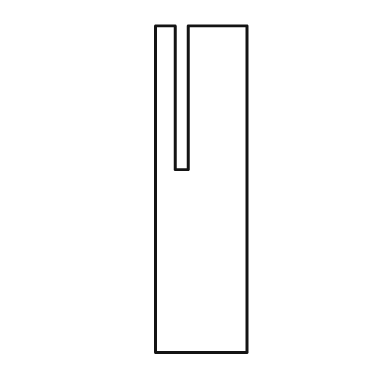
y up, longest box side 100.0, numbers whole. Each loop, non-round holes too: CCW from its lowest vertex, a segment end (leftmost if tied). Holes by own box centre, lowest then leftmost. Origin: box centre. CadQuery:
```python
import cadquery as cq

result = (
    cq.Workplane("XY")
    .moveTo(-14.0, -50.0)
    .lineTo(14.0, -50.0)
    .lineTo(14.0, 50.0)
    .lineTo(-4.0, 50.0)
    .lineTo(-4.0, 6.0)
    .lineTo(-8.0, 6.0)
    .lineTo(-8.0, 50.0)
    .lineTo(-14.0, 50.0)
    .close()
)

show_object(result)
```